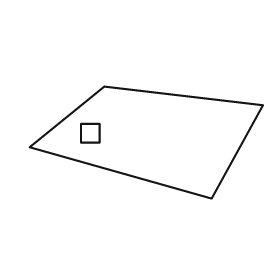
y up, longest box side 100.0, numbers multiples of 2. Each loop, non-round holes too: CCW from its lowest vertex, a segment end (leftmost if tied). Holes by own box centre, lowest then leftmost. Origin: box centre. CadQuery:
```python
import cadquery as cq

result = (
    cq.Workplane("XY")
    .moveTo(28.0, -24.0)
    .lineTo(50.0, 16.0)
    .lineTo(-18.0, 24.0)
    .lineTo(-50.0, -2.0)
    .close()
    .moveTo(-28.0, 0.0)
    .lineTo(-20.0, 0.0)
    .lineTo(-20.0, 8.0)
    .lineTo(-28.0, 8.0)
    .close()
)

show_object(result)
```